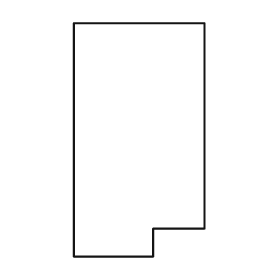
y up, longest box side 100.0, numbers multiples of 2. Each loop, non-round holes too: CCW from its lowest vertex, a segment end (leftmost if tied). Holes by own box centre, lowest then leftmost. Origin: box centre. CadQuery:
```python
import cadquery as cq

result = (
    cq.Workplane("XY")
    .moveTo(-28.0, -50.0)
    .lineTo(6.0, -50.0)
    .lineTo(6.0, -38.0)
    .lineTo(28.0, -38.0)
    .lineTo(28.0, 50.0)
    .lineTo(-28.0, 50.0)
    .close()
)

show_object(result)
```